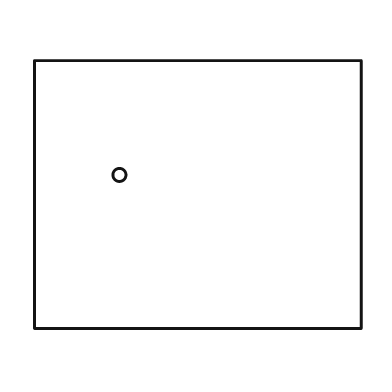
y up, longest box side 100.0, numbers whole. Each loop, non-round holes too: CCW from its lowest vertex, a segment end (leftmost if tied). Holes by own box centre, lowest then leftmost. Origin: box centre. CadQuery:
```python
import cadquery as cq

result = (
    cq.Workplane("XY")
    .moveTo(-50.0, -41.0)
    .lineTo(50.0, -41.0)
    .lineTo(50.0, 41.0)
    .lineTo(-50.0, 41.0)
    .close()
    .moveTo(-24.0, 6.0)
    .circle(2.0)
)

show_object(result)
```